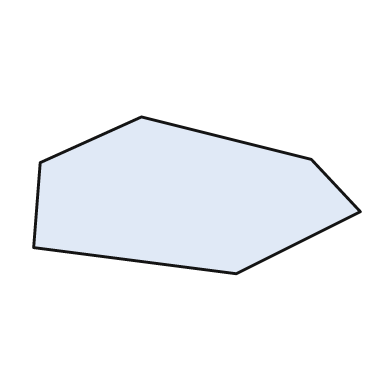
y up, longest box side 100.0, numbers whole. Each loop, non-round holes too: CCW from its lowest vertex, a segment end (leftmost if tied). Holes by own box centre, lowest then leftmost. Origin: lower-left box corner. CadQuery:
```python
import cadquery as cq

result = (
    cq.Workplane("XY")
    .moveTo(62.0, 0.0)
    .lineTo(100.0, 19.0)
    .lineTo(85.0, 35.0)
    .lineTo(33.0, 48.0)
    .lineTo(2.0, 34.0)
    .lineTo(0.0, 8.0)
    .close()
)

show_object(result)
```